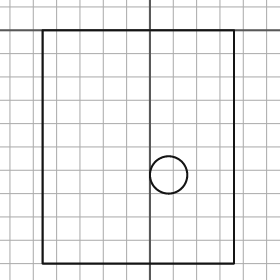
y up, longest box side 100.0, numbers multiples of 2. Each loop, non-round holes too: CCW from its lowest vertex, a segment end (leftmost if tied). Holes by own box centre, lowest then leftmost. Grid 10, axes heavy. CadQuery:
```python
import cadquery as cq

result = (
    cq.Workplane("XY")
    .moveTo(-46.0, -100.0)
    .lineTo(36.0, -100.0)
    .lineTo(36.0, 0.0)
    .lineTo(-46.0, 0.0)
    .close()
    .moveTo(8.0, -62.0)
    .circle(8.0)
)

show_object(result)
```